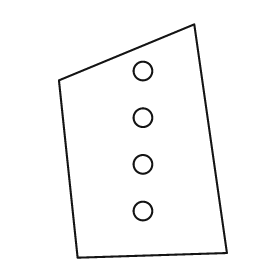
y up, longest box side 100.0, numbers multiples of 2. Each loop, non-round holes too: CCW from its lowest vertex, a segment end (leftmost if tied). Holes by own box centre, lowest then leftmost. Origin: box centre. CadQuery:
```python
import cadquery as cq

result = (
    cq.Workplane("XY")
    .moveTo(-28.0, -50.0)
    .lineTo(36.0, -48.0)
    .lineTo(22.0, 50.0)
    .lineTo(-36.0, 26.0)
    .close()
    .moveTo(0.0, -30.0)
    .circle(4.0)
    .moveTo(0.0, -10.0)
    .circle(4.0)
    .moveTo(0.0, 10.0)
    .circle(4.0)
    .moveTo(0.0, 30.0)
    .circle(4.0)
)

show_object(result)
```